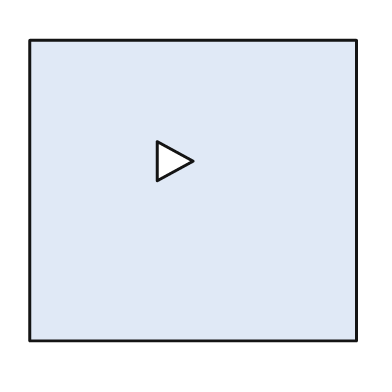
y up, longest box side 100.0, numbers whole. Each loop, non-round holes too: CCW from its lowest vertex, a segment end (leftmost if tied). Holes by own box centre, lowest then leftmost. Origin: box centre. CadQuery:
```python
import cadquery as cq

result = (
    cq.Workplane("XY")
    .moveTo(-50.0, -46.0)
    .lineTo(50.0, -46.0)
    .lineTo(50.0, 46.0)
    .lineTo(-50.0, 46.0)
    .close()
    .moveTo(-11.0, 3.0)
    .lineTo(0.0, 9.0)
    .lineTo(-11.0, 15.0)
    .close()
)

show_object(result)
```